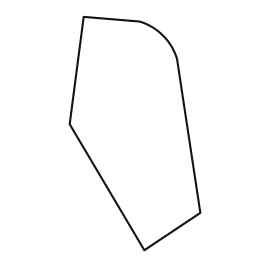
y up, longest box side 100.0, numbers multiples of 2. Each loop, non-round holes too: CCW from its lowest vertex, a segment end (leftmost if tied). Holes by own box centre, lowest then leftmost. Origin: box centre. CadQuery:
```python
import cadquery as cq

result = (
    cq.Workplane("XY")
    .moveTo(4.0, -50.0)
    .lineTo(28.0, -34.0)
    .lineTo(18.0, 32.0)
    .threePointArc((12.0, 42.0), (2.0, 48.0))
    .lineTo(-22.0, 50.0)
    .lineTo(-28.0, 4.0)
    .close()
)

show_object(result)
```